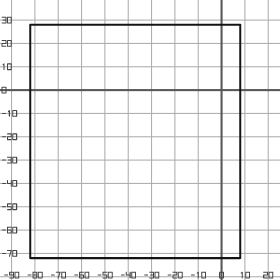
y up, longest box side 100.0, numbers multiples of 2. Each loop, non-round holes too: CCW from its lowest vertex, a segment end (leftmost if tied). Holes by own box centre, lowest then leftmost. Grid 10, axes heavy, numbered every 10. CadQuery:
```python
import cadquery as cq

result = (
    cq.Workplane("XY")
    .moveTo(-82.0, -72.0)
    .lineTo(8.0, -72.0)
    .lineTo(8.0, 28.0)
    .lineTo(-82.0, 28.0)
    .close()
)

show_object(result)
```